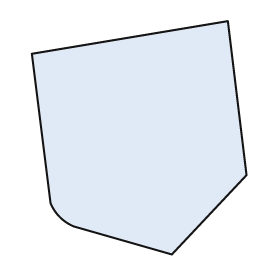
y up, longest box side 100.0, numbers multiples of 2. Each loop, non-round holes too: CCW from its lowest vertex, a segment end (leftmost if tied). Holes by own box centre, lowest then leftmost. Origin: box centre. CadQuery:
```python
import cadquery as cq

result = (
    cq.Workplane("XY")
    .moveTo(14.0, -50.0)
    .lineTo(46.0, -16.0)
    .lineTo(38.0, 50.0)
    .lineTo(-46.0, 36.0)
    .lineTo(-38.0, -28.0)
    .threePointArc((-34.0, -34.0), (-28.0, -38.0))
    .close()
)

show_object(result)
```